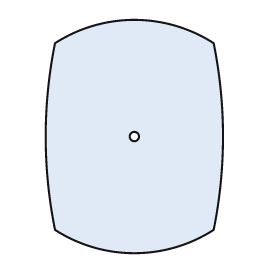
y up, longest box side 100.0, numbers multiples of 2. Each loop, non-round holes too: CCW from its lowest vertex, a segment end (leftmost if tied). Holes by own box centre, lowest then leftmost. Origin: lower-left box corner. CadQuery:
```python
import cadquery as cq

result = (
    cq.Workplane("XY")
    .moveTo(4.0, 10.0)
    .threePointArc((38.0, 0.0), (72.0, 10.0))
    .threePointArc((76.0, 50.0), (72.0, 90.0))
    .threePointArc((38.0, 100.0), (4.0, 90.0))
    .threePointArc((0.0, 50.0), (4.0, 10.0))
    .close()
    .moveTo(38.0, 50.0)
    .circle(2.0)
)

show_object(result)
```